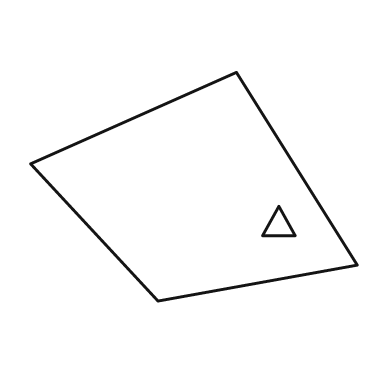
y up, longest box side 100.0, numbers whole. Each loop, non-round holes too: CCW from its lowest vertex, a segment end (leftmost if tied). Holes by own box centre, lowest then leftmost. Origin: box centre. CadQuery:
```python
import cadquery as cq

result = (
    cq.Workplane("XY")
    .moveTo(-11.0, -35.0)
    .lineTo(50.0, -24.0)
    .lineTo(13.0, 35.0)
    .lineTo(-50.0, 7.0)
    .close()
    .moveTo(21.0, -15.0)
    .lineTo(31.0, -15.0)
    .lineTo(26.0, -6.0)
    .close()
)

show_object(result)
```